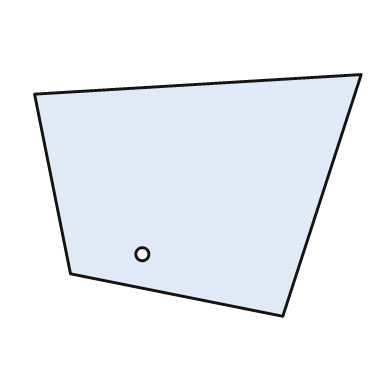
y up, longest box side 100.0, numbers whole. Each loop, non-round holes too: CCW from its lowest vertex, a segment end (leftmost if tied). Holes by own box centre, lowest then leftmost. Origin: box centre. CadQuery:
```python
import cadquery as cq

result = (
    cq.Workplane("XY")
    .moveTo(26.0, -37.0)
    .lineTo(50.0, 37.0)
    .lineTo(-50.0, 31.0)
    .lineTo(-39.0, -24.0)
    .close()
    .moveTo(-17.0, -18.0)
    .circle(2.0)
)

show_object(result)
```